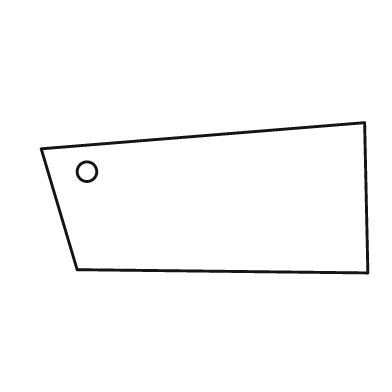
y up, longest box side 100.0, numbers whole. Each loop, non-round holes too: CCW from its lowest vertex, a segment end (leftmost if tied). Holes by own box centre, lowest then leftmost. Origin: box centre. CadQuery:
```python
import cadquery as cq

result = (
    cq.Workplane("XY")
    .moveTo(50.0, -23.0)
    .lineTo(49.0, 23.0)
    .lineTo(-50.0, 15.0)
    .lineTo(-39.0, -22.0)
    .close()
    .moveTo(-36.0, 8.0)
    .circle(3.0)
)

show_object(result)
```